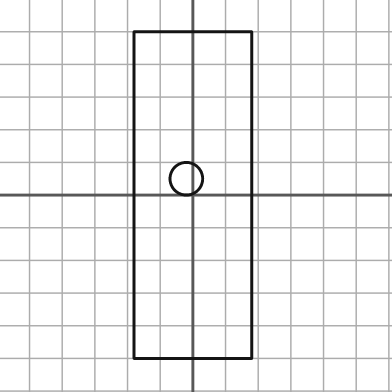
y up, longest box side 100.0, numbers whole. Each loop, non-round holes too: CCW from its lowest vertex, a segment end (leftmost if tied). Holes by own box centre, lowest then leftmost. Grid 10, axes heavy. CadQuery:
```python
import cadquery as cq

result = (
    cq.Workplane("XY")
    .moveTo(-18.0, -50.0)
    .lineTo(18.0, -50.0)
    .lineTo(18.0, 50.0)
    .lineTo(-18.0, 50.0)
    .close()
    .moveTo(-2.0, 5.0)
    .circle(5.0)
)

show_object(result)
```